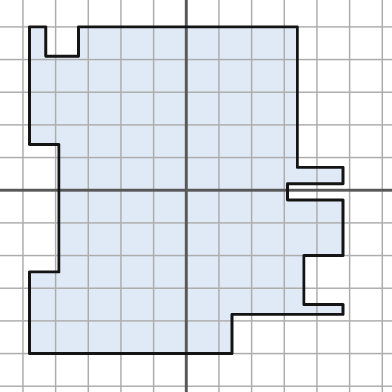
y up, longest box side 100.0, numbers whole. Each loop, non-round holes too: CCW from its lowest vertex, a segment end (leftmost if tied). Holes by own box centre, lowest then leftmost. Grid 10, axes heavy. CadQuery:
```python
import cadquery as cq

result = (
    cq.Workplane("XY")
    .moveTo(-48.0, -50.0)
    .lineTo(14.0, -50.0)
    .lineTo(14.0, -38.0)
    .lineTo(48.0, -38.0)
    .lineTo(48.0, -35.0)
    .lineTo(36.0, -35.0)
    .lineTo(36.0, -20.0)
    .lineTo(48.0, -20.0)
    .lineTo(48.0, -3.0)
    .lineTo(31.0, -3.0)
    .lineTo(31.0, 2.0)
    .lineTo(48.0, 2.0)
    .lineTo(48.0, 7.0)
    .lineTo(34.0, 7.0)
    .lineTo(34.0, 50.0)
    .lineTo(-33.0, 50.0)
    .lineTo(-33.0, 41.0)
    .lineTo(-43.0, 41.0)
    .lineTo(-43.0, 50.0)
    .lineTo(-48.0, 50.0)
    .lineTo(-48.0, 14.0)
    .lineTo(-39.0, 14.0)
    .lineTo(-39.0, -25.0)
    .lineTo(-48.0, -25.0)
    .close()
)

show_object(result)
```